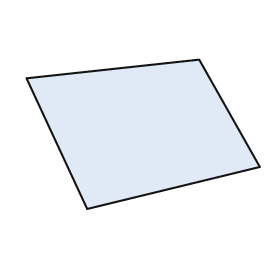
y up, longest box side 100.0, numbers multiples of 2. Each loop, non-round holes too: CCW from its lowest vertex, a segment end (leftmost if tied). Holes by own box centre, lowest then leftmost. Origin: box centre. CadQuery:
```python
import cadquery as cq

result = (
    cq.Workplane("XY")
    .moveTo(-24.0, -32.0)
    .lineTo(50.0, -14.0)
    .lineTo(24.0, 32.0)
    .lineTo(-50.0, 24.0)
    .close()
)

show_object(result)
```